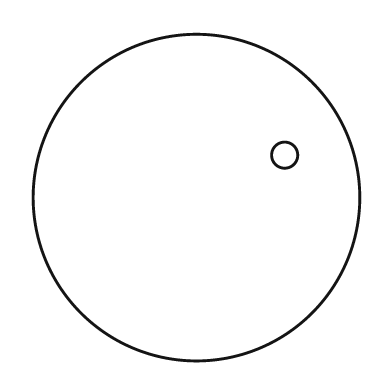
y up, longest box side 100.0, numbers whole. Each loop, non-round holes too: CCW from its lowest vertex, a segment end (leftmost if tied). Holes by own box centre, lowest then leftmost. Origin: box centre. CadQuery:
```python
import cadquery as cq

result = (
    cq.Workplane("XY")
    .moveTo(0.0, 0.0)
    .circle(50.0)
    .moveTo(27.0, 13.0)
    .circle(4.0)
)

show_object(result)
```